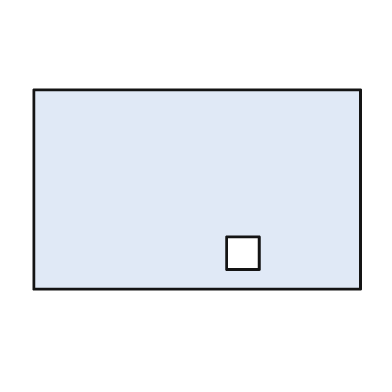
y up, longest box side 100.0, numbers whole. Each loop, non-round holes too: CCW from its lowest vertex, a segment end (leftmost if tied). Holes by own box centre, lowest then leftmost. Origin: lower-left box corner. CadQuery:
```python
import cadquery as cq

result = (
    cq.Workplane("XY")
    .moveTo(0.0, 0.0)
    .lineTo(100.0, 0.0)
    .lineTo(100.0, 61.0)
    .lineTo(0.0, 61.0)
    .close()
    .moveTo(59.0, 6.0)
    .lineTo(69.0, 6.0)
    .lineTo(69.0, 16.0)
    .lineTo(59.0, 16.0)
    .close()
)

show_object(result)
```